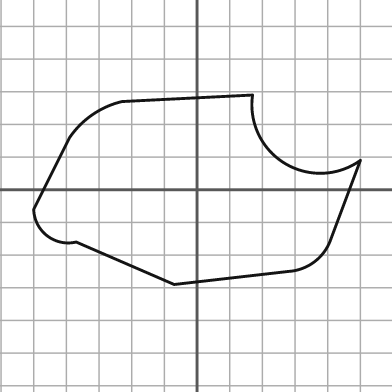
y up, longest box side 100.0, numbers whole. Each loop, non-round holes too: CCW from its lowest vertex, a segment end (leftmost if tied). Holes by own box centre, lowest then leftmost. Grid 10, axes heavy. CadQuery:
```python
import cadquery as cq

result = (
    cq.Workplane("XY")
    .moveTo(-7.0, -29.0)
    .lineTo(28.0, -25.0)
    .threePointArc((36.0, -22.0), (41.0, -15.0))
    .lineTo(50.0, 9.0)
    .threePointArc((27.0, 8.0), (17.0, 29.0))
    .lineTo(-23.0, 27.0)
    .threePointArc((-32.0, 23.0), (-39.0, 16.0))
    .lineTo(-50.0, -6.0)
    .threePointArc((-46.0, -14.0), (-37.0, -16.0))
    .close()
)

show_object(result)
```